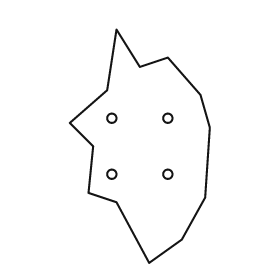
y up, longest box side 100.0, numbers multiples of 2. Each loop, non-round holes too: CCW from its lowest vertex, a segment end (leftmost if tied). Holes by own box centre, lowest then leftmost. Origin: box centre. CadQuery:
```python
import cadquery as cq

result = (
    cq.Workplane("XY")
    .moveTo(4.0, -50.0)
    .lineTo(18.0, -40.0)
    .lineTo(28.0, -22.0)
    .lineTo(30.0, 8.0)
    .lineTo(26.0, 22.0)
    .lineTo(12.0, 38.0)
    .lineTo(0.0, 34.0)
    .lineTo(-10.0, 50.0)
    .lineTo(-14.0, 24.0)
    .lineTo(-30.0, 10.0)
    .lineTo(-20.0, 0.0)
    .lineTo(-22.0, -20.0)
    .lineTo(-10.0, -24.0)
    .close()
    .moveTo(-12.0, -12.0)
    .circle(2.0)
    .moveTo(12.0, -12.0)
    .circle(2.0)
    .moveTo(-12.0, 12.0)
    .circle(2.0)
    .moveTo(12.0, 12.0)
    .circle(2.0)
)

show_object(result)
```